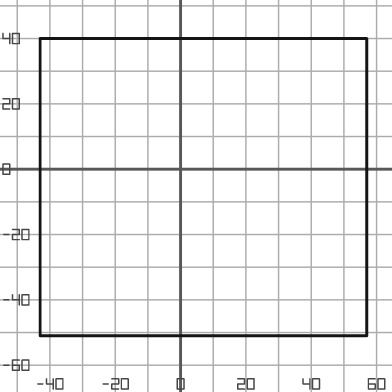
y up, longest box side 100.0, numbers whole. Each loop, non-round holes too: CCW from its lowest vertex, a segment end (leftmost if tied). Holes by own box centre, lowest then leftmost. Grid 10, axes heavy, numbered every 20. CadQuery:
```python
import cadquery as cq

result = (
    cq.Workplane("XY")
    .moveTo(-43.0, -51.0)
    .lineTo(57.0, -51.0)
    .lineTo(57.0, 40.0)
    .lineTo(-43.0, 40.0)
    .close()
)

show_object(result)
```